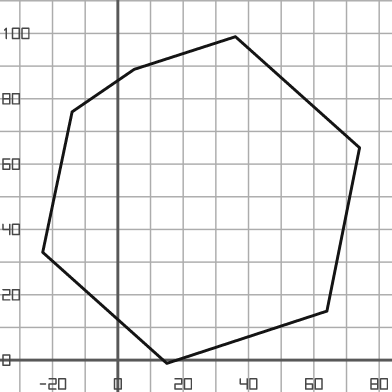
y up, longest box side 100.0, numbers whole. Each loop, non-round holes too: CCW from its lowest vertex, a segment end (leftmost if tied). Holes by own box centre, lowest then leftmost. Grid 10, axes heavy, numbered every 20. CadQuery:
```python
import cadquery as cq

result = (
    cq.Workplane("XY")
    .moveTo(15.0, -1.0)
    .lineTo(64.0, 15.0)
    .lineTo(74.0, 65.0)
    .lineTo(36.0, 99.0)
    .lineTo(5.0, 89.0)
    .lineTo(-14.0, 76.0)
    .lineTo(-23.0, 33.0)
    .close()
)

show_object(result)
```